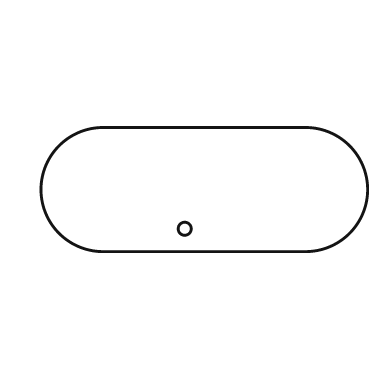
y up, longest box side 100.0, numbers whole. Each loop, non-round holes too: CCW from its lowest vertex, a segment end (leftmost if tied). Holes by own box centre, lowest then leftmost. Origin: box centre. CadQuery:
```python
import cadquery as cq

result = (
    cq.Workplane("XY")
    .moveTo(-31.0, -19.0)
    .lineTo(31.0, -19.0)
    .threePointArc((50.0, 0.0), (31.0, 19.0))
    .lineTo(-31.0, 19.0)
    .threePointArc((-50.0, 0.0), (-31.0, -19.0))
    .close()
    .moveTo(-6.0, -12.0)
    .circle(2.0)
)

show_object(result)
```